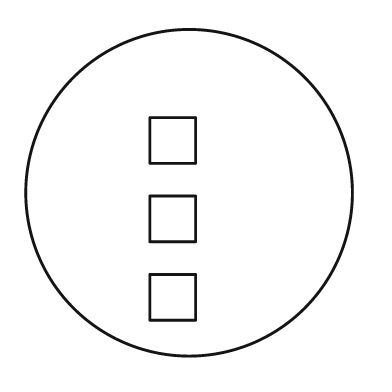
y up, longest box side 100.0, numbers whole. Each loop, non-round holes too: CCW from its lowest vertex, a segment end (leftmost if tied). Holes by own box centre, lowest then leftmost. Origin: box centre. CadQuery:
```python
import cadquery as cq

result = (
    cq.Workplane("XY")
    .moveTo(0.0, 0.0)
    .circle(50.0)
    .moveTo(-12.0, -39.0)
    .lineTo(2.0, -39.0)
    .lineTo(2.0, -25.0)
    .lineTo(-12.0, -25.0)
    .close()
    .moveTo(-12.0, -15.0)
    .lineTo(2.0, -15.0)
    .lineTo(2.0, -1.0)
    .lineTo(-12.0, -1.0)
    .close()
    .moveTo(-12.0, 9.0)
    .lineTo(2.0, 9.0)
    .lineTo(2.0, 23.0)
    .lineTo(-12.0, 23.0)
    .close()
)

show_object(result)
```